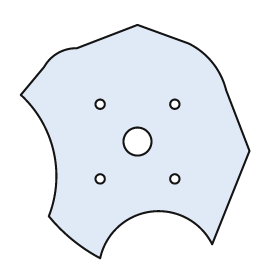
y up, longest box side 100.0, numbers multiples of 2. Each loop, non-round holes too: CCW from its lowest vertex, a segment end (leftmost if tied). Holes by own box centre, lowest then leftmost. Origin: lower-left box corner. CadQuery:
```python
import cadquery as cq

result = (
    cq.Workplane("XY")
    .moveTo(34.0, 0.0)
    .threePointArc((56.0, 20.0), (82.0, 6.0))
    .lineTo(98.0, 46.0)
    .lineTo(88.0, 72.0)
    .threePointArc((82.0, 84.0), (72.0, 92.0))
    .lineTo(50.0, 100.0)
    .lineTo(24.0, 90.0)
    .threePointArc((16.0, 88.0), (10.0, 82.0))
    .lineTo(0.0, 70.0)
    .threePointArc((14.0, 46.0), (12.0, 18.0))
    .threePointArc((22.0, 8.0), (34.0, 0.0))
    .close()
    .moveTo(34.0, 34.0)
    .circle(2.0)
    .moveTo(66.0, 34.0)
    .circle(2.0)
    .moveTo(50.0, 50.0)
    .circle(6.0)
    .moveTo(34.0, 66.0)
    .circle(2.0)
    .moveTo(66.0, 66.0)
    .circle(2.0)
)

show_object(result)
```